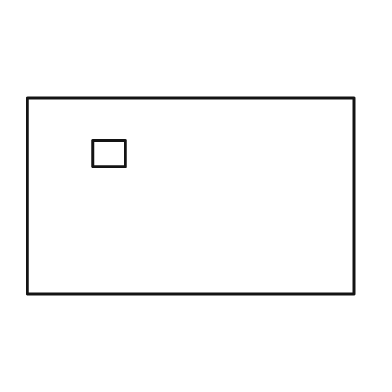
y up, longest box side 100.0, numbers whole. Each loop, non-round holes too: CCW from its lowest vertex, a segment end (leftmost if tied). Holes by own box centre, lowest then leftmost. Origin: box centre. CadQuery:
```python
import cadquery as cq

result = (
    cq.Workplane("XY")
    .moveTo(-50.0, -30.0)
    .lineTo(50.0, -30.0)
    .lineTo(50.0, 30.0)
    .lineTo(-50.0, 30.0)
    .close()
    .moveTo(-30.0, 9.0)
    .lineTo(-20.0, 9.0)
    .lineTo(-20.0, 17.0)
    .lineTo(-30.0, 17.0)
    .close()
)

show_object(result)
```